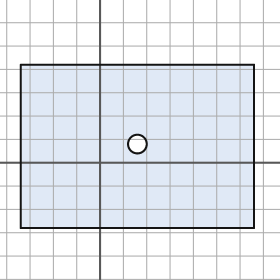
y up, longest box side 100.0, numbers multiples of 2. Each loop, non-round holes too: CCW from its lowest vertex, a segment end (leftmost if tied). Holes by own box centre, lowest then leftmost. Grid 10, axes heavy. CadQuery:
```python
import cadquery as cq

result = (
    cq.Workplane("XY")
    .moveTo(-34.0, -28.0)
    .lineTo(66.0, -28.0)
    .lineTo(66.0, 42.0)
    .lineTo(-34.0, 42.0)
    .close()
    .moveTo(16.0, 8.0)
    .circle(4.0)
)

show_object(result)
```